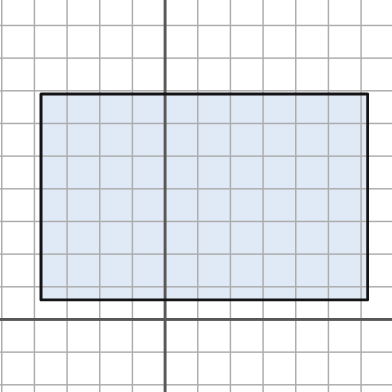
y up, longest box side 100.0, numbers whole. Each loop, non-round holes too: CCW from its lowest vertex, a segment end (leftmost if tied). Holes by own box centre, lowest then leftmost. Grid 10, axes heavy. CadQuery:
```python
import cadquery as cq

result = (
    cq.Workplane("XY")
    .moveTo(-38.0, 6.0)
    .lineTo(62.0, 6.0)
    .lineTo(62.0, 69.0)
    .lineTo(-38.0, 69.0)
    .close()
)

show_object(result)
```